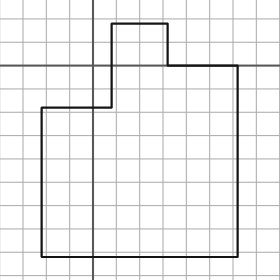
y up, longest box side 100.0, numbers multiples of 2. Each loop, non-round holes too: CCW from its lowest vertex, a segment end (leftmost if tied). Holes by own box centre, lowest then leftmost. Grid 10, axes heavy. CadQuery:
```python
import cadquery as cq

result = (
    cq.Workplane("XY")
    .moveTo(-22.0, -82.0)
    .lineTo(62.0, -82.0)
    .lineTo(62.0, 0.0)
    .lineTo(32.0, 0.0)
    .lineTo(32.0, 18.0)
    .lineTo(8.0, 18.0)
    .lineTo(8.0, -18.0)
    .lineTo(-22.0, -18.0)
    .close()
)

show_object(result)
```